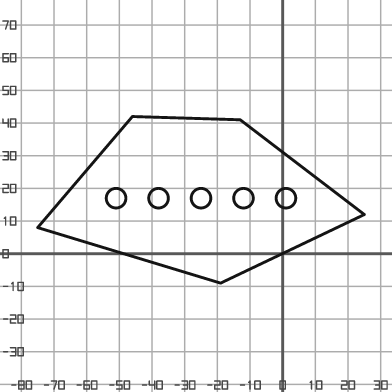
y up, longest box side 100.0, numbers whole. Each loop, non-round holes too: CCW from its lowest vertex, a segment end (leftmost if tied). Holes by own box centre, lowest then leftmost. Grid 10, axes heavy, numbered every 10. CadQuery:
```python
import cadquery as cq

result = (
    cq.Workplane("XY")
    .moveTo(-19.0, -9.0)
    .lineTo(25.0, 12.0)
    .lineTo(-13.0, 41.0)
    .lineTo(-46.0, 42.0)
    .lineTo(-75.0, 8.0)
    .close()
    .moveTo(-51.0, 17.0)
    .circle(3.0)
    .moveTo(-38.0, 17.0)
    .circle(3.0)
    .moveTo(-25.0, 17.0)
    .circle(3.0)
    .moveTo(-12.0, 17.0)
    .circle(3.0)
    .moveTo(1.0, 17.0)
    .circle(3.0)
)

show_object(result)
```